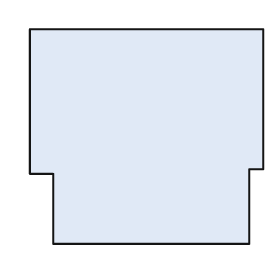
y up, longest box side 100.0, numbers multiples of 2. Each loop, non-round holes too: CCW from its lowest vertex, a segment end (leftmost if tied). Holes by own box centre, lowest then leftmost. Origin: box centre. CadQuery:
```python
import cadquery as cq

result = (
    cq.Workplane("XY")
    .moveTo(-40.0, -46.0)
    .lineTo(44.0, -46.0)
    .lineTo(44.0, -14.0)
    .lineTo(50.0, -14.0)
    .lineTo(50.0, 46.0)
    .lineTo(-50.0, 46.0)
    .lineTo(-50.0, -16.0)
    .lineTo(-40.0, -16.0)
    .close()
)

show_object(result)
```